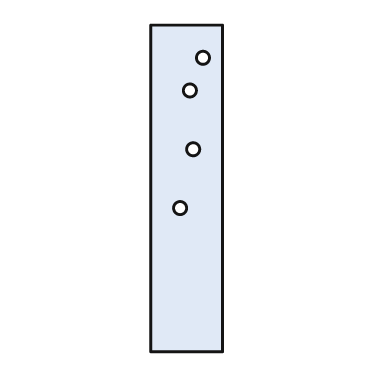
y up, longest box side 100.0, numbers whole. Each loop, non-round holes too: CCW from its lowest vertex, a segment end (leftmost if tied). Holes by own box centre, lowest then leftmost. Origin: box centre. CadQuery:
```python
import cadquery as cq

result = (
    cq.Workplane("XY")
    .moveTo(-11.0, -50.0)
    .lineTo(11.0, -50.0)
    .lineTo(11.0, 50.0)
    .lineTo(-11.0, 50.0)
    .close()
    .moveTo(-2.0, -6.0)
    .circle(2.0)
    .moveTo(2.0, 12.0)
    .circle(2.0)
    .moveTo(1.0, 30.0)
    .circle(2.0)
    .moveTo(5.0, 40.0)
    .circle(2.0)
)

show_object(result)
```